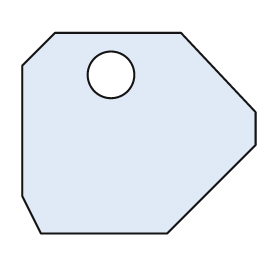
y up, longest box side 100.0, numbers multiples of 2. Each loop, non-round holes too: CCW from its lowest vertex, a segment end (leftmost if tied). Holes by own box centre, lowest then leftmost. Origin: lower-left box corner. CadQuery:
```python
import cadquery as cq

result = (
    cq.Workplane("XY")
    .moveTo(8.0, 0.0)
    .lineTo(62.0, 0.0)
    .lineTo(100.0, 38.0)
    .lineTo(100.0, 52.0)
    .lineTo(68.0, 86.0)
    .lineTo(14.0, 86.0)
    .lineTo(0.0, 72.0)
    .lineTo(0.0, 16.0)
    .close()
    .moveTo(38.0, 68.0)
    .circle(10.0)
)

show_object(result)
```